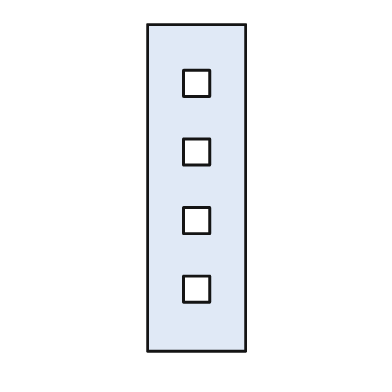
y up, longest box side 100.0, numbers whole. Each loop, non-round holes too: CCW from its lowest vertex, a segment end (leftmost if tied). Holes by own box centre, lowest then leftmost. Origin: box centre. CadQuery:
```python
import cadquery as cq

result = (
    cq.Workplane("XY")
    .moveTo(-15.0, -50.0)
    .lineTo(15.0, -50.0)
    .lineTo(15.0, 50.0)
    .lineTo(-15.0, 50.0)
    .close()
    .moveTo(-4.0, -35.0)
    .lineTo(4.0, -35.0)
    .lineTo(4.0, -27.0)
    .lineTo(-4.0, -27.0)
    .close()
    .moveTo(-4.0, -14.0)
    .lineTo(4.0, -14.0)
    .lineTo(4.0, -6.0)
    .lineTo(-4.0, -6.0)
    .close()
    .moveTo(-4.0, 7.0)
    .lineTo(4.0, 7.0)
    .lineTo(4.0, 15.0)
    .lineTo(-4.0, 15.0)
    .close()
    .moveTo(-4.0, 28.0)
    .lineTo(4.0, 28.0)
    .lineTo(4.0, 36.0)
    .lineTo(-4.0, 36.0)
    .close()
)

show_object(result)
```